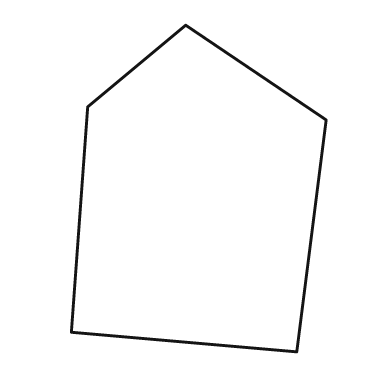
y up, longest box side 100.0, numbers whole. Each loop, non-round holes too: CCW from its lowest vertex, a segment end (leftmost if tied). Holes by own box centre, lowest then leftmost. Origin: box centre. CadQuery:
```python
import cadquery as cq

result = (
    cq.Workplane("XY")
    .moveTo(30.0, -50.0)
    .lineTo(39.0, 21.0)
    .lineTo(-4.0, 50.0)
    .lineTo(-34.0, 25.0)
    .lineTo(-39.0, -44.0)
    .close()
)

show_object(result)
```